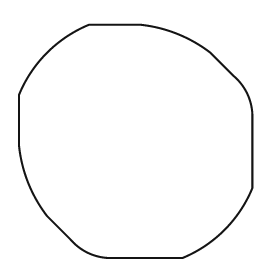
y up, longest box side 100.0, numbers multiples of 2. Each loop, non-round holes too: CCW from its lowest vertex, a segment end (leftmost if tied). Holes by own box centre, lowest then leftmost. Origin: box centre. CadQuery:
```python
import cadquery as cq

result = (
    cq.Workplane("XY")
    .moveTo(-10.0, -50.0)
    .lineTo(20.0, -50.0)
    .threePointArc((38.0, -38.0), (50.0, -20.0))
    .lineTo(50.0, 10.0)
    .threePointArc((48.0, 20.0), (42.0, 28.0))
    .lineTo(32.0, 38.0)
    .threePointArc((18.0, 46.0), (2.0, 50.0))
    .lineTo(-20.0, 50.0)
    .threePointArc((-38.0, 38.0), (-50.0, 20.0))
    .lineTo(-50.0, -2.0)
    .threePointArc((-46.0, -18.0), (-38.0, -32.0))
    .lineTo(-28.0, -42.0)
    .threePointArc((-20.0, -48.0), (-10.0, -50.0))
    .close()
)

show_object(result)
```